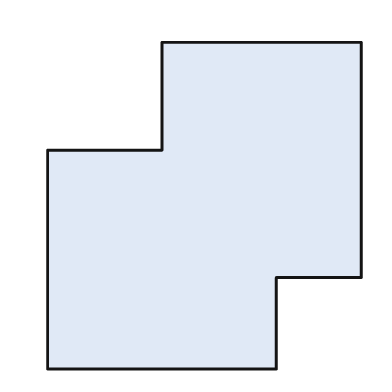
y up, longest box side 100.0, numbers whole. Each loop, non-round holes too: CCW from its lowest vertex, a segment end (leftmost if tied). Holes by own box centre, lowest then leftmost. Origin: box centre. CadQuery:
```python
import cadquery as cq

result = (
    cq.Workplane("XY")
    .moveTo(-48.0, -50.0)
    .lineTo(22.0, -50.0)
    .lineTo(22.0, -22.0)
    .lineTo(48.0, -22.0)
    .lineTo(48.0, 50.0)
    .lineTo(-13.0, 50.0)
    .lineTo(-13.0, 17.0)
    .lineTo(-48.0, 17.0)
    .close()
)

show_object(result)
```